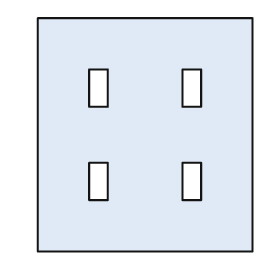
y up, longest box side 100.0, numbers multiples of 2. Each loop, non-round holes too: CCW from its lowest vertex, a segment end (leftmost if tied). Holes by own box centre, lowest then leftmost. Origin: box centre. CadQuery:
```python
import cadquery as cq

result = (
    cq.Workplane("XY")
    .moveTo(-46.0, -50.0)
    .lineTo(46.0, -50.0)
    .lineTo(46.0, 50.0)
    .lineTo(-46.0, 50.0)
    .close()
    .moveTo(-24.0, -28.0)
    .lineTo(-16.0, -28.0)
    .lineTo(-16.0, -12.0)
    .lineTo(-24.0, -12.0)
    .close()
    .moveTo(16.0, -28.0)
    .lineTo(24.0, -28.0)
    .lineTo(24.0, -12.0)
    .lineTo(16.0, -12.0)
    .close()
    .moveTo(-24.0, 12.0)
    .lineTo(-16.0, 12.0)
    .lineTo(-16.0, 28.0)
    .lineTo(-24.0, 28.0)
    .close()
    .moveTo(16.0, 12.0)
    .lineTo(24.0, 12.0)
    .lineTo(24.0, 28.0)
    .lineTo(16.0, 28.0)
    .close()
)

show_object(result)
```